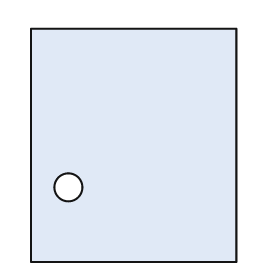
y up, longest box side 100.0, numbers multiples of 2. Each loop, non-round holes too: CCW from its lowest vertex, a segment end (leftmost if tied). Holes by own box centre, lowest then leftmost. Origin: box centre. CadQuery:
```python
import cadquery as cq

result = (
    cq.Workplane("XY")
    .moveTo(-44.0, -50.0)
    .lineTo(44.0, -50.0)
    .lineTo(44.0, 50.0)
    .lineTo(-44.0, 50.0)
    .close()
    .moveTo(-28.0, -18.0)
    .circle(6.0)
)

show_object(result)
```